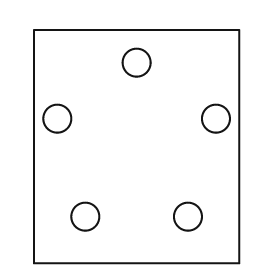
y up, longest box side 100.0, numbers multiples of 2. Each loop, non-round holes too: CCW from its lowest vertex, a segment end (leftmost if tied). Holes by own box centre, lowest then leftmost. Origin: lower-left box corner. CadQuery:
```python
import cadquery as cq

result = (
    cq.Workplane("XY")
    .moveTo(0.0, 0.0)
    .lineTo(88.0, 0.0)
    .lineTo(88.0, 100.0)
    .lineTo(0.0, 100.0)
    .close()
    .moveTo(22.0, 20.0)
    .circle(6.0)
    .moveTo(66.0, 20.0)
    .circle(6.0)
    .moveTo(10.0, 62.0)
    .circle(6.0)
    .moveTo(78.0, 62.0)
    .circle(6.0)
    .moveTo(44.0, 86.0)
    .circle(6.0)
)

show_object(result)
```